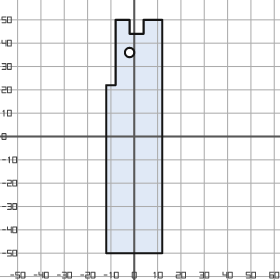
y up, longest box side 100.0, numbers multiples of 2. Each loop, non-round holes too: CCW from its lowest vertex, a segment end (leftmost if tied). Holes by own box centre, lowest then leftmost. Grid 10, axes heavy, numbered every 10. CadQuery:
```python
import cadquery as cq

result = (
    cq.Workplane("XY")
    .moveTo(-12.0, -50.0)
    .lineTo(12.0, -50.0)
    .lineTo(12.0, 50.0)
    .lineTo(4.0, 50.0)
    .lineTo(4.0, 44.0)
    .lineTo(-2.0, 44.0)
    .lineTo(-2.0, 50.0)
    .lineTo(-8.0, 50.0)
    .lineTo(-8.0, 22.0)
    .lineTo(-12.0, 22.0)
    .close()
    .moveTo(-2.0, 36.0)
    .circle(2.0)
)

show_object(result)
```